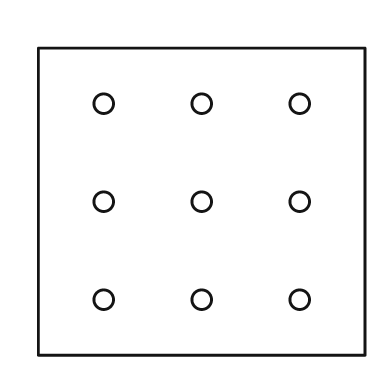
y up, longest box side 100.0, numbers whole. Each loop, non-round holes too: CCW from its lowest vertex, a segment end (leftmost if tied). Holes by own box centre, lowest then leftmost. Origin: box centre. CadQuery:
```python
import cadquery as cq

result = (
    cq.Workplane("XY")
    .moveTo(-50.0, -47.0)
    .lineTo(50.0, -47.0)
    .lineTo(50.0, 47.0)
    .lineTo(-50.0, 47.0)
    .close()
    .moveTo(-30.0, -30.0)
    .circle(3.0)
    .moveTo(0.0, -30.0)
    .circle(3.0)
    .moveTo(30.0, -30.0)
    .circle(3.0)
    .moveTo(-30.0, 0.0)
    .circle(3.0)
    .moveTo(0.0, 0.0)
    .circle(3.0)
    .moveTo(30.0, 0.0)
    .circle(3.0)
    .moveTo(-30.0, 30.0)
    .circle(3.0)
    .moveTo(0.0, 30.0)
    .circle(3.0)
    .moveTo(30.0, 30.0)
    .circle(3.0)
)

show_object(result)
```